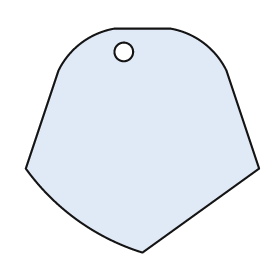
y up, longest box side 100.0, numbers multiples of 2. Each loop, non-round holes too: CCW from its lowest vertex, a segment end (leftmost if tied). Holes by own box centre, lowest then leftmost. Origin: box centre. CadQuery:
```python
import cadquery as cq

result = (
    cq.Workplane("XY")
    .moveTo(0.0, -48.0)
    .lineTo(50.0, -12.0)
    .lineTo(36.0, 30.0)
    .threePointArc((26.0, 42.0), (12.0, 48.0))
    .lineTo(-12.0, 48.0)
    .threePointArc((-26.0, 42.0), (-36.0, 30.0))
    .lineTo(-50.0, -12.0)
    .threePointArc((-28.0, -34.0), (0.0, -48.0))
    .close()
    .moveTo(-8.0, 38.0)
    .circle(4.0)
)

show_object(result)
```